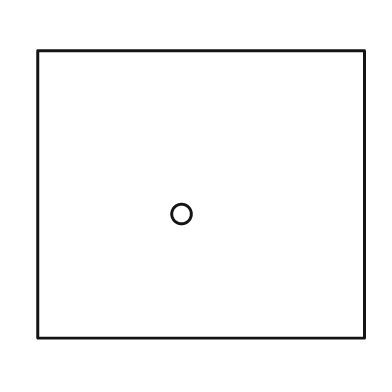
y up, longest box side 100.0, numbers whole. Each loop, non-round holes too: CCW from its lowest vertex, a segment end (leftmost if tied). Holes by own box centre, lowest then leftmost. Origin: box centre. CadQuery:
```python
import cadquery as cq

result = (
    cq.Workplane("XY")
    .moveTo(-50.0, -44.0)
    .lineTo(50.0, -44.0)
    .lineTo(50.0, 44.0)
    .lineTo(-50.0, 44.0)
    .close()
    .moveTo(-6.0, -6.0)
    .circle(3.0)
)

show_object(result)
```